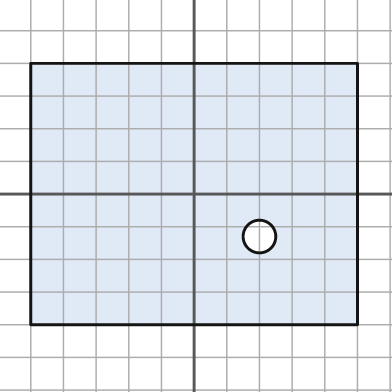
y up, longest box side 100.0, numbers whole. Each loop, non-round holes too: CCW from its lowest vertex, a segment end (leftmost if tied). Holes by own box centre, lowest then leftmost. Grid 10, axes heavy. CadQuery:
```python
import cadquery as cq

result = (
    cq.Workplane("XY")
    .moveTo(-50.0, -40.0)
    .lineTo(50.0, -40.0)
    .lineTo(50.0, 40.0)
    .lineTo(-50.0, 40.0)
    .close()
    .moveTo(20.0, -13.0)
    .circle(5.0)
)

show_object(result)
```